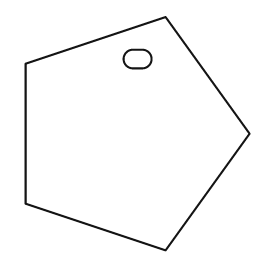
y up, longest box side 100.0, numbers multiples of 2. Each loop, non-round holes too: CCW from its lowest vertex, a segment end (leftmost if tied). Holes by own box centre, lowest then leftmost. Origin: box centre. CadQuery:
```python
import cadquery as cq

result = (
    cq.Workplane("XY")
    .moveTo(12.0, -50.0)
    .lineTo(48.0, 0.0)
    .lineTo(12.0, 50.0)
    .lineTo(-48.0, 30.0)
    .lineTo(-48.0, -30.0)
    .close()
    .moveTo(-2.0, 28.0)
    .lineTo(2.0, 28.0)
    .threePointArc((6.0, 32.0), (2.0, 36.0))
    .lineTo(-2.0, 36.0)
    .threePointArc((-6.0, 32.0), (-2.0, 28.0))
    .close()
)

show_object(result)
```